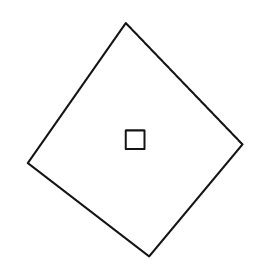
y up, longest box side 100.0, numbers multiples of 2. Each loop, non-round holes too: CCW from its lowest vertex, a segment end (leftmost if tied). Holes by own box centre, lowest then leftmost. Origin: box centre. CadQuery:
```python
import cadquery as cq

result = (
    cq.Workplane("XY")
    .moveTo(6.0, -50.0)
    .lineTo(46.0, -2.0)
    .lineTo(-4.0, 50.0)
    .lineTo(-46.0, -10.0)
    .close()
    .moveTo(-4.0, -4.0)
    .lineTo(4.0, -4.0)
    .lineTo(4.0, 4.0)
    .lineTo(-4.0, 4.0)
    .close()
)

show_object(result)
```